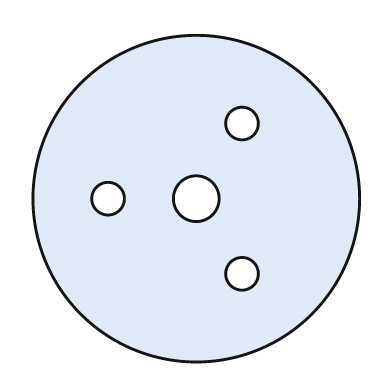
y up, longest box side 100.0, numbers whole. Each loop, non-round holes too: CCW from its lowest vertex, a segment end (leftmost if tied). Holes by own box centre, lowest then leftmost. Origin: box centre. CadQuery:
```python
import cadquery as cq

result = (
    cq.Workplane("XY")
    .moveTo(0.0, 0.0)
    .circle(50.0)
    .moveTo(14.0, -23.0)
    .circle(5.0)
    .moveTo(-27.0, 0.0)
    .circle(5.0)
    .moveTo(0.0, 0.0)
    .circle(7.0)
    .moveTo(14.0, 23.0)
    .circle(5.0)
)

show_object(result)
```